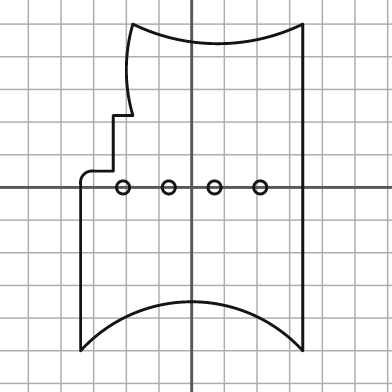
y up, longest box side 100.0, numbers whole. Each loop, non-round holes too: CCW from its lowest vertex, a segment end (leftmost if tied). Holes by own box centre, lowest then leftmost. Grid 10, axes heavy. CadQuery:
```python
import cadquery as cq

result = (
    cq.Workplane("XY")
    .moveTo(-34.0, -50.0)
    .threePointArc((0.0, -35.0), (34.0, -50.0))
    .lineTo(34.0, 50.0)
    .threePointArc((8.0, 44.0), (-18.0, 50.0))
    .threePointArc((-20.0, 36.0), (-18.0, 22.0))
    .lineTo(-24.0, 22.0)
    .lineTo(-24.0, 5.0)
    .lineTo(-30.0, 5.0)
    .threePointArc((-33.0, 4.0), (-34.0, 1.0))
    .close()
    .moveTo(-21.0, 0.0)
    .circle(2.0)
    .moveTo(-7.0, 0.0)
    .circle(2.0)
    .moveTo(7.0, 0.0)
    .circle(2.0)
    .moveTo(21.0, 0.0)
    .circle(2.0)
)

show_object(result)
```